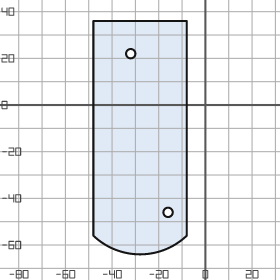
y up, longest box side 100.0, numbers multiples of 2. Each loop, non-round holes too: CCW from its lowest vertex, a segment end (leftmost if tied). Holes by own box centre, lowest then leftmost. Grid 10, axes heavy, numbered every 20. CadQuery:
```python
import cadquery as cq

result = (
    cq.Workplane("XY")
    .moveTo(-48.0, -56.0)
    .threePointArc((-28.0, -64.0), (-8.0, -56.0))
    .lineTo(-8.0, 36.0)
    .lineTo(-48.0, 36.0)
    .close()
    .moveTo(-16.0, -46.0)
    .circle(2.0)
    .moveTo(-32.0, 22.0)
    .circle(2.0)
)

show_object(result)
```